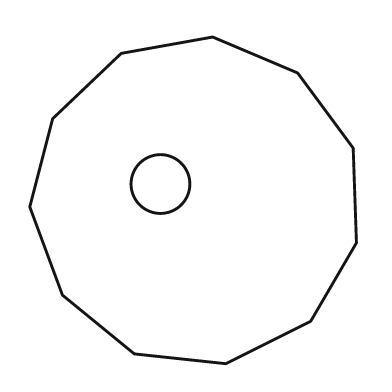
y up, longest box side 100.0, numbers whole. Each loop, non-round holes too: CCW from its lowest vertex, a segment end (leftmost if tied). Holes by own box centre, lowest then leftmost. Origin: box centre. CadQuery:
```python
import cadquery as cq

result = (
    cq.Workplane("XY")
    .moveTo(10.0, -50.0)
    .lineTo(36.0, -37.0)
    .lineTo(50.0, -13.0)
    .lineTo(49.0, 16.0)
    .lineTo(32.0, 39.0)
    .lineTo(6.0, 50.0)
    .lineTo(-22.0, 45.0)
    .lineTo(-43.0, 25.0)
    .lineTo(-50.0, -2.0)
    .lineTo(-40.0, -29.0)
    .lineTo(-18.0, -47.0)
    .close()
    .moveTo(-10.0, 5.0)
    .circle(9.0)
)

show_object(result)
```